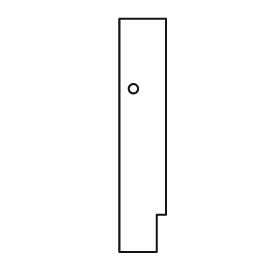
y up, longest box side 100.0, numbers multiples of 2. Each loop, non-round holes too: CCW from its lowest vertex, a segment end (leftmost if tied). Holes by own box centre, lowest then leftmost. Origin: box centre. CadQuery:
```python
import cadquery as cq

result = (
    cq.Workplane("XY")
    .moveTo(-10.0, -50.0)
    .lineTo(6.0, -50.0)
    .lineTo(6.0, -34.0)
    .lineTo(10.0, -34.0)
    .lineTo(10.0, 50.0)
    .lineTo(-10.0, 50.0)
    .close()
    .moveTo(-4.0, 20.0)
    .circle(2.0)
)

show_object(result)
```